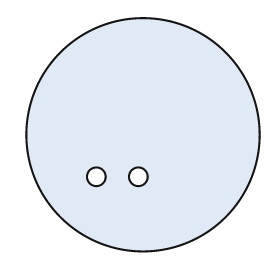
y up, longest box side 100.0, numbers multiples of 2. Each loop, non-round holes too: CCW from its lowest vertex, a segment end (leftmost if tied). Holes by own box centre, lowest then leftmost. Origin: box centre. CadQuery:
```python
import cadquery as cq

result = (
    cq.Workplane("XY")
    .moveTo(0.0, 0.0)
    .circle(50.0)
    .moveTo(-20.0, -18.0)
    .circle(4.0)
    .moveTo(-2.0, -18.0)
    .circle(4.0)
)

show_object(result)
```